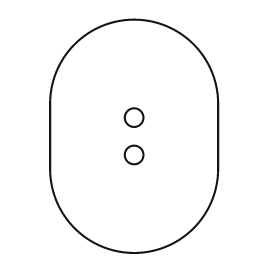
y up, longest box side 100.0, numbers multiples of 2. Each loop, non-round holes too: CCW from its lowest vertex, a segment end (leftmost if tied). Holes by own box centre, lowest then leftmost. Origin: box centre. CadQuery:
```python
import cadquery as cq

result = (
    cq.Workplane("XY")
    .moveTo(-36.0, -14.0)
    .threePointArc((0.0, -50.0), (36.0, -14.0))
    .lineTo(36.0, 14.0)
    .threePointArc((0.0, 50.0), (-36.0, 14.0))
    .close()
    .moveTo(0.0, -8.0)
    .circle(4.0)
    .moveTo(0.0, 8.0)
    .circle(4.0)
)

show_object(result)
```